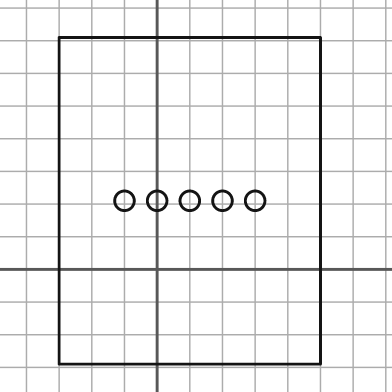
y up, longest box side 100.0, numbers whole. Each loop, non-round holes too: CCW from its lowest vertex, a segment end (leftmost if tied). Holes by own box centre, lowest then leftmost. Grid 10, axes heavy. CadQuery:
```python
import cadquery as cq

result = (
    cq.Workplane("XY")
    .moveTo(-30.0, -29.0)
    .lineTo(50.0, -29.0)
    .lineTo(50.0, 71.0)
    .lineTo(-30.0, 71.0)
    .close()
    .moveTo(-10.0, 21.0)
    .circle(3.0)
    .moveTo(0.0, 21.0)
    .circle(3.0)
    .moveTo(10.0, 21.0)
    .circle(3.0)
    .moveTo(20.0, 21.0)
    .circle(3.0)
    .moveTo(30.0, 21.0)
    .circle(3.0)
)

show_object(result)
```